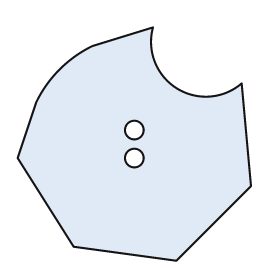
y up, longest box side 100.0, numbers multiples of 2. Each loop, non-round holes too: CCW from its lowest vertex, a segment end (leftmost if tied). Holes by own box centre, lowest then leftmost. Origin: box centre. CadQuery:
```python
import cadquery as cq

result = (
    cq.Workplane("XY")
    .moveTo(18.0, -50.0)
    .lineTo(50.0, -18.0)
    .lineTo(46.0, 26.0)
    .threePointArc((18.0, 24.0), (8.0, 50.0))
    .lineTo(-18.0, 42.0)
    .threePointArc((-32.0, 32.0), (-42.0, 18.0))
    .lineTo(-50.0, -6.0)
    .lineTo(-26.0, -44.0)
    .close()
    .moveTo(0.0, -6.0)
    .circle(4.0)
    .moveTo(0.0, 6.0)
    .circle(4.0)
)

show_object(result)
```